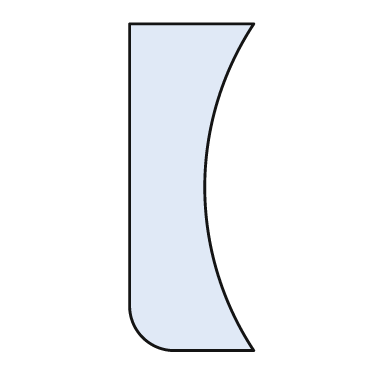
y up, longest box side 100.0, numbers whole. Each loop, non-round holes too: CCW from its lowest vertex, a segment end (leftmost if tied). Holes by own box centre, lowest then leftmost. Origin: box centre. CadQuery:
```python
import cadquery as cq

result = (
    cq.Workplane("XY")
    .moveTo(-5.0, -50.0)
    .lineTo(19.0, -50.0)
    .threePointArc((4.0, 0.0), (19.0, 50.0))
    .lineTo(-19.0, 50.0)
    .lineTo(-19.0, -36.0)
    .threePointArc((-15.0, -46.0), (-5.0, -50.0))
    .close()
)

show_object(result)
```